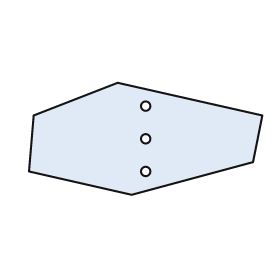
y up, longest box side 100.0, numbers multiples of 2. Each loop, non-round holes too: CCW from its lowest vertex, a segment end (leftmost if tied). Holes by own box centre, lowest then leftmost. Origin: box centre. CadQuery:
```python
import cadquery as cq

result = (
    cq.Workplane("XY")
    .moveTo(-6.0, -24.0)
    .lineTo(46.0, -10.0)
    .lineTo(50.0, 10.0)
    .lineTo(-12.0, 24.0)
    .lineTo(-48.0, 10.0)
    .lineTo(-50.0, -14.0)
    .close()
    .moveTo(0.0, -14.0)
    .circle(2.0)
    .moveTo(0.0, 0.0)
    .circle(2.0)
    .moveTo(0.0, 14.0)
    .circle(2.0)
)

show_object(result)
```